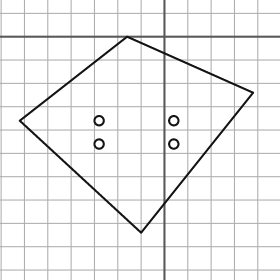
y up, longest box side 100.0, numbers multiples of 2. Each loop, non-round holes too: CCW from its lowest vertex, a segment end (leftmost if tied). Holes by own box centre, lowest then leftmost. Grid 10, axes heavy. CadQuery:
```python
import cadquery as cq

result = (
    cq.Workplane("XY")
    .moveTo(-10.0, -84.0)
    .lineTo(38.0, -24.0)
    .lineTo(-16.0, 0.0)
    .lineTo(-62.0, -36.0)
    .close()
    .moveTo(-28.0, -46.0)
    .circle(2.0)
    .moveTo(4.0, -46.0)
    .circle(2.0)
    .moveTo(-28.0, -36.0)
    .circle(2.0)
    .moveTo(4.0, -36.0)
    .circle(2.0)
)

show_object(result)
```